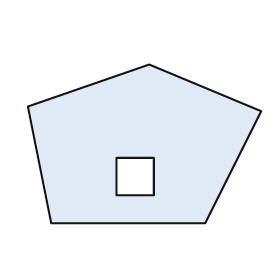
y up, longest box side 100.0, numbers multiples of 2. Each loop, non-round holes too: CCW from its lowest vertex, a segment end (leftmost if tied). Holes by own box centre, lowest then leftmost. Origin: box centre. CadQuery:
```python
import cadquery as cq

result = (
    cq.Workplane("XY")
    .moveTo(-40.0, -34.0)
    .lineTo(26.0, -34.0)
    .lineTo(50.0, 14.0)
    .lineTo(2.0, 34.0)
    .lineTo(-50.0, 16.0)
    .close()
    .moveTo(-12.0, -22.0)
    .lineTo(4.0, -22.0)
    .lineTo(4.0, -6.0)
    .lineTo(-12.0, -6.0)
    .close()
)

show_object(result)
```